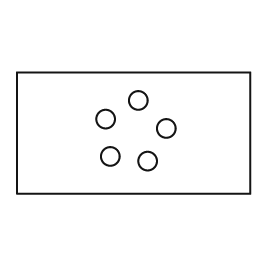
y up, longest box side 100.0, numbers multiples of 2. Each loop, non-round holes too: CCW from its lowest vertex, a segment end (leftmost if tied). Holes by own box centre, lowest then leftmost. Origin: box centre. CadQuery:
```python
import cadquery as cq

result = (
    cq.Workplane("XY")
    .moveTo(-50.0, -26.0)
    .lineTo(50.0, -26.0)
    .lineTo(50.0, 26.0)
    .lineTo(-50.0, 26.0)
    .close()
    .moveTo(6.0, -12.0)
    .circle(4.0)
    .moveTo(-10.0, -10.0)
    .circle(4.0)
    .moveTo(14.0, 2.0)
    .circle(4.0)
    .moveTo(-12.0, 6.0)
    .circle(4.0)
    .moveTo(2.0, 14.0)
    .circle(4.0)
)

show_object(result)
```